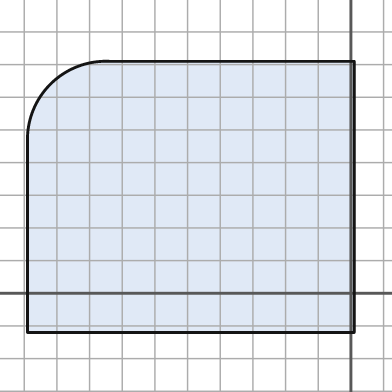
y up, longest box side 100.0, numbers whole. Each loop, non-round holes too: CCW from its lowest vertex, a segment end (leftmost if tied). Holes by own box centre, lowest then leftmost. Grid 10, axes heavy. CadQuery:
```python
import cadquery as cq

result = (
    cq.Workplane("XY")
    .moveTo(-99.0, -12.0)
    .lineTo(1.0, -12.0)
    .lineTo(1.0, 71.0)
    .lineTo(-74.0, 71.0)
    .threePointArc((-92.0, 64.0), (-99.0, 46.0))
    .close()
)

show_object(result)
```